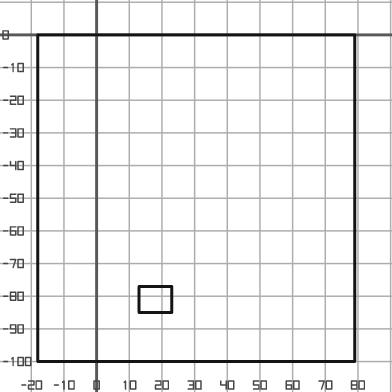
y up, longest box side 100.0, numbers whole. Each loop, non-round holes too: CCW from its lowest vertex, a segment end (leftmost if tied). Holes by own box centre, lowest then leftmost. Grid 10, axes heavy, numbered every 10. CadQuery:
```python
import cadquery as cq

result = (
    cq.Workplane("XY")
    .moveTo(-18.0, -100.0)
    .lineTo(79.0, -100.0)
    .lineTo(79.0, 0.0)
    .lineTo(-18.0, 0.0)
    .close()
    .moveTo(13.0, -85.0)
    .lineTo(23.0, -85.0)
    .lineTo(23.0, -77.0)
    .lineTo(13.0, -77.0)
    .close()
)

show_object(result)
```